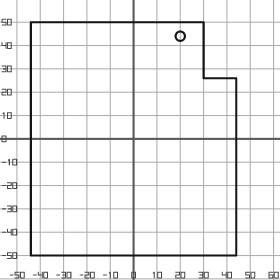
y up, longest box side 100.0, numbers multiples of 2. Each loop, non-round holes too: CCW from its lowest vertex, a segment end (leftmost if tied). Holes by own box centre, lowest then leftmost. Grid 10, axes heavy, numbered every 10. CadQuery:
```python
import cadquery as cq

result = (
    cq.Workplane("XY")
    .moveTo(-44.0, -50.0)
    .lineTo(44.0, -50.0)
    .lineTo(44.0, 26.0)
    .lineTo(30.0, 26.0)
    .lineTo(30.0, 50.0)
    .lineTo(-44.0, 50.0)
    .close()
    .moveTo(20.0, 44.0)
    .circle(2.0)
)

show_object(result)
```